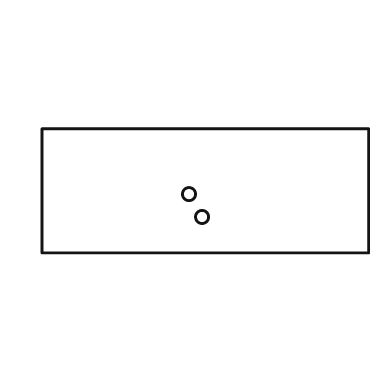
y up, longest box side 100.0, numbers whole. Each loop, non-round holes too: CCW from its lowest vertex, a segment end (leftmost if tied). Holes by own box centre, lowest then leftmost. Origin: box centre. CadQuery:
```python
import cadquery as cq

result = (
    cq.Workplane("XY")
    .moveTo(-50.0, -19.0)
    .lineTo(50.0, -19.0)
    .lineTo(50.0, 19.0)
    .lineTo(-50.0, 19.0)
    .close()
    .moveTo(-1.0, -8.0)
    .circle(2.0)
    .moveTo(-5.0, -1.0)
    .circle(2.0)
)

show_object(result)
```